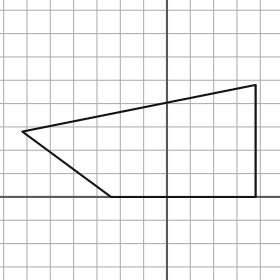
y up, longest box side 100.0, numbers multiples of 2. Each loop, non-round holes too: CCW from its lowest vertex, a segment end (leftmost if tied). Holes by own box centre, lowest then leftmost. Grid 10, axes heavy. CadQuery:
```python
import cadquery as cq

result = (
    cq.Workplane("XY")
    .moveTo(-24.0, 0.0)
    .lineTo(38.0, 0.0)
    .lineTo(38.0, 48.0)
    .lineTo(-62.0, 28.0)
    .close()
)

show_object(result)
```